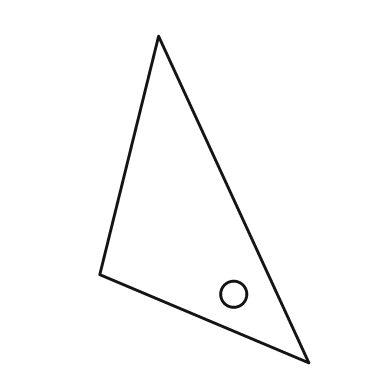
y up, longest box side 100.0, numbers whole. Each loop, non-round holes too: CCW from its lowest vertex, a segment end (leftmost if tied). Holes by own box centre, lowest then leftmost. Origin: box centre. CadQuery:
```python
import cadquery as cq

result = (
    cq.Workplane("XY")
    .moveTo(32.0, -50.0)
    .lineTo(-14.0, 50.0)
    .lineTo(-32.0, -23.0)
    .close()
    .moveTo(9.0, -29.0)
    .circle(4.0)
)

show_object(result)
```